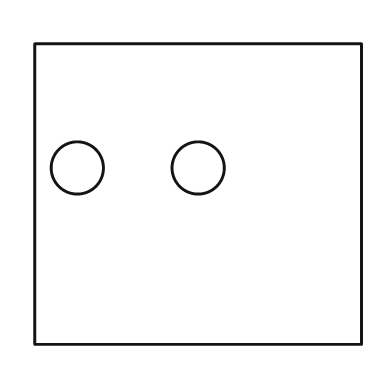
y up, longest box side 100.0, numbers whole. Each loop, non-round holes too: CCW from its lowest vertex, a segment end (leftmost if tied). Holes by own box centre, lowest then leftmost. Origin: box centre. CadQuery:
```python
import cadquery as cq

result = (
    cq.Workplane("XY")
    .moveTo(-50.0, -46.0)
    .lineTo(50.0, -46.0)
    .lineTo(50.0, 46.0)
    .lineTo(-50.0, 46.0)
    .close()
    .moveTo(-37.0, 8.0)
    .circle(8.0)
    .moveTo(0.0, 8.0)
    .circle(8.0)
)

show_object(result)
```